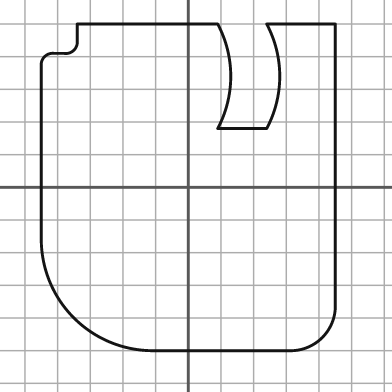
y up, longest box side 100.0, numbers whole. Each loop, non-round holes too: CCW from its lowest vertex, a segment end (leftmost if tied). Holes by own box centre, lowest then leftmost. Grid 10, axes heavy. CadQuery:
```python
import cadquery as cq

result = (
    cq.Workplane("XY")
    .moveTo(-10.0, -50.0)
    .lineTo(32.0, -50.0)
    .threePointArc((41.0, -46.0), (45.0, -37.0))
    .lineTo(45.0, 50.0)
    .lineTo(24.0, 50.0)
    .threePointArc((28.0, 34.0), (24.0, 18.0))
    .lineTo(9.0, 18.0)
    .threePointArc((13.0, 34.0), (9.0, 50.0))
    .lineTo(-34.0, 50.0)
    .lineTo(-34.0, 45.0)
    .threePointArc((-35.0, 42.0), (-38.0, 41.0))
    .lineTo(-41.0, 41.0)
    .threePointArc((-44.0, 40.0), (-45.0, 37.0))
    .lineTo(-45.0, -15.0)
    .threePointArc((-35.0, -40.0), (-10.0, -50.0))
    .close()
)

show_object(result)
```